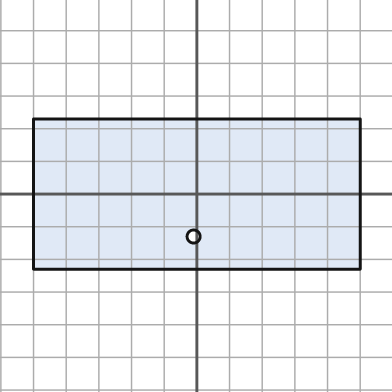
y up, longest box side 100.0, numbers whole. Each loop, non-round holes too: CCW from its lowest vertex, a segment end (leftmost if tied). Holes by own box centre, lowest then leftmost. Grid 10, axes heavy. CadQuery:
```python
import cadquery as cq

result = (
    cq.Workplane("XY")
    .moveTo(-50.0, -23.0)
    .lineTo(50.0, -23.0)
    .lineTo(50.0, 23.0)
    .lineTo(-50.0, 23.0)
    .close()
    .moveTo(-1.0, -13.0)
    .circle(2.0)
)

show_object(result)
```